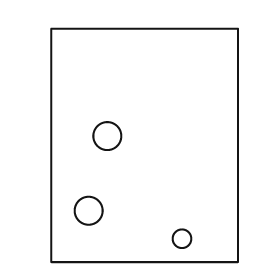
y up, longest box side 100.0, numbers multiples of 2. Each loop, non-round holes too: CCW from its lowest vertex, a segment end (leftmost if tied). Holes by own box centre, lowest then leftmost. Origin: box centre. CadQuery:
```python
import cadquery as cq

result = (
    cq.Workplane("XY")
    .moveTo(-40.0, -50.0)
    .lineTo(40.0, -50.0)
    .lineTo(40.0, 50.0)
    .lineTo(-40.0, 50.0)
    .close()
    .moveTo(16.0, -40.0)
    .circle(4.0)
    .moveTo(-24.0, -28.0)
    .circle(6.0)
    .moveTo(-16.0, 4.0)
    .circle(6.0)
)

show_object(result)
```